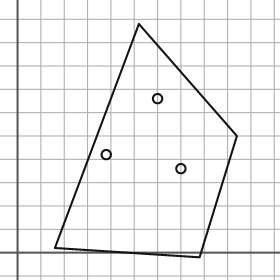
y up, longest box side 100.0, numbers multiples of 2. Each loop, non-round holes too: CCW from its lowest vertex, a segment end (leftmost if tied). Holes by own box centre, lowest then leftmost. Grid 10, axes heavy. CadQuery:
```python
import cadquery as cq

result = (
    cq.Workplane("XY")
    .moveTo(78.0, -2.0)
    .lineTo(94.0, 50.0)
    .lineTo(52.0, 98.0)
    .lineTo(16.0, 2.0)
    .close()
    .moveTo(70.0, 36.0)
    .circle(2.0)
    .moveTo(38.0, 42.0)
    .circle(2.0)
    .moveTo(60.0, 66.0)
    .circle(2.0)
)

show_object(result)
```